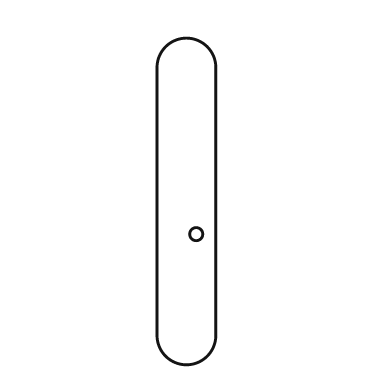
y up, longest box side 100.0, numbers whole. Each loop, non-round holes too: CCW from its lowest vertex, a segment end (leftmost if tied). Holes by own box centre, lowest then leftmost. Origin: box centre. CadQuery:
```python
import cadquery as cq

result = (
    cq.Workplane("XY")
    .moveTo(-9.0, -41.0)
    .threePointArc((0.0, -50.0), (9.0, -41.0))
    .lineTo(9.0, 41.0)
    .threePointArc((0.0, 50.0), (-9.0, 41.0))
    .close()
    .moveTo(3.0, -10.0)
    .circle(2.0)
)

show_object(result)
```